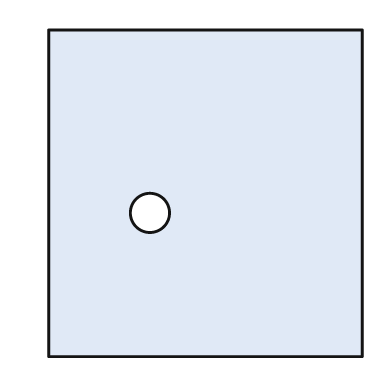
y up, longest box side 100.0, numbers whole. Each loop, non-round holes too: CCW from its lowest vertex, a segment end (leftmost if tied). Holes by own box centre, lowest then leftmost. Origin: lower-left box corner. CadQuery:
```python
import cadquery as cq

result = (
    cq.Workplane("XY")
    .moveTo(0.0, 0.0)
    .lineTo(96.0, 0.0)
    .lineTo(96.0, 100.0)
    .lineTo(0.0, 100.0)
    .close()
    .moveTo(31.0, 44.0)
    .circle(6.0)
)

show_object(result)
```